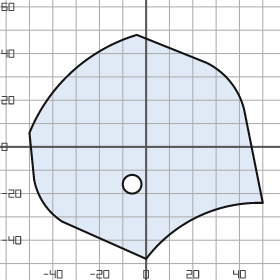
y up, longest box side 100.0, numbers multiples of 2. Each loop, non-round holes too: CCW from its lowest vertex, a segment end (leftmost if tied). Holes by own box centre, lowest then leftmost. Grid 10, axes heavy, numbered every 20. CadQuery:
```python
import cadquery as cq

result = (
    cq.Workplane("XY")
    .moveTo(0.0, -48.0)
    .threePointArc((22.0, -30.0), (50.0, -24.0))
    .lineTo(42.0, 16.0)
    .threePointArc((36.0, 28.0), (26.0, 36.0))
    .lineTo(-4.0, 48.0)
    .threePointArc((-32.0, 32.0), (-50.0, 6.0))
    .lineTo(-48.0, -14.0)
    .threePointArc((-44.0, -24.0), (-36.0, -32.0))
    .close()
    .moveTo(-6.0, -16.0)
    .circle(4.0)
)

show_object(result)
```